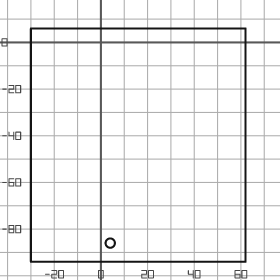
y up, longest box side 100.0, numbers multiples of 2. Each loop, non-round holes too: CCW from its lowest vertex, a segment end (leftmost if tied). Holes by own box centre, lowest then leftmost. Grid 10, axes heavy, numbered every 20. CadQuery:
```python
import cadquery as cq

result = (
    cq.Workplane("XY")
    .moveTo(-30.0, -94.0)
    .lineTo(62.0, -94.0)
    .lineTo(62.0, 6.0)
    .lineTo(-30.0, 6.0)
    .close()
    .moveTo(4.0, -86.0)
    .circle(2.0)
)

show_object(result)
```